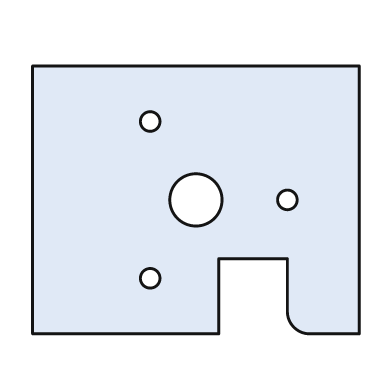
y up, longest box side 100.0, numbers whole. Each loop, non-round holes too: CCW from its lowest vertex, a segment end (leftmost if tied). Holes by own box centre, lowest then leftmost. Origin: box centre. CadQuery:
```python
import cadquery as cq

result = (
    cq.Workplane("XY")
    .moveTo(-50.0, -41.0)
    .lineTo(7.0, -41.0)
    .lineTo(7.0, -18.0)
    .lineTo(28.0, -18.0)
    .lineTo(28.0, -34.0)
    .threePointArc((30.0, -39.0), (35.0, -41.0))
    .lineTo(50.0, -41.0)
    .lineTo(50.0, 41.0)
    .lineTo(-50.0, 41.0)
    .close()
    .moveTo(-14.0, -24.0)
    .circle(3.0)
    .moveTo(0.0, 0.0)
    .circle(8.0)
    .moveTo(28.0, 0.0)
    .circle(3.0)
    .moveTo(-14.0, 24.0)
    .circle(3.0)
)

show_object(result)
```